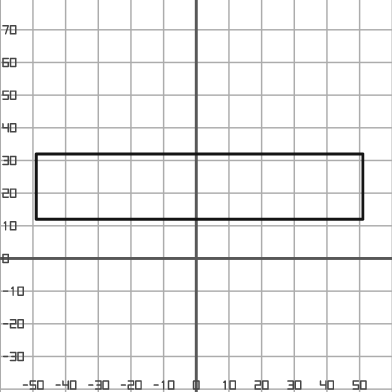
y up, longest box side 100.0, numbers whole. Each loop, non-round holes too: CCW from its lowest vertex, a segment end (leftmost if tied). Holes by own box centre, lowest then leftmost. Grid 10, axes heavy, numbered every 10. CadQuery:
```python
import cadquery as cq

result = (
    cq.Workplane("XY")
    .moveTo(-49.0, 12.0)
    .lineTo(51.0, 12.0)
    .lineTo(51.0, 32.0)
    .lineTo(-49.0, 32.0)
    .close()
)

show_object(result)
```